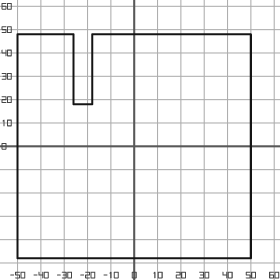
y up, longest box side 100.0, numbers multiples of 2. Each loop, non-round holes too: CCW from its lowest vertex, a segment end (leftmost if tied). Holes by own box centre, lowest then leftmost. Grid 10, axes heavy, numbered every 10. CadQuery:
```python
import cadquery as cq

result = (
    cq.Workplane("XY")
    .moveTo(-50.0, -48.0)
    .lineTo(50.0, -48.0)
    .lineTo(50.0, 48.0)
    .lineTo(-18.0, 48.0)
    .lineTo(-18.0, 18.0)
    .lineTo(-26.0, 18.0)
    .lineTo(-26.0, 48.0)
    .lineTo(-50.0, 48.0)
    .close()
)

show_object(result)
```